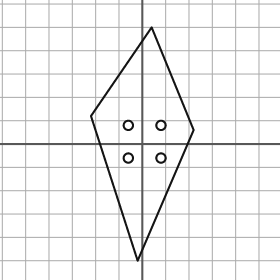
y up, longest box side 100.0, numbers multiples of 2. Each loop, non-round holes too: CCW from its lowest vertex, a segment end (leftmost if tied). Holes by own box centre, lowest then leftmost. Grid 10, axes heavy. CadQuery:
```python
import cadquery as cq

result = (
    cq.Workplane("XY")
    .moveTo(-2.0, -50.0)
    .lineTo(22.0, 6.0)
    .lineTo(4.0, 50.0)
    .lineTo(-22.0, 12.0)
    .close()
    .moveTo(-6.0, -6.0)
    .circle(2.0)
    .moveTo(8.0, -6.0)
    .circle(2.0)
    .moveTo(-6.0, 8.0)
    .circle(2.0)
    .moveTo(8.0, 8.0)
    .circle(2.0)
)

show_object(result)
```